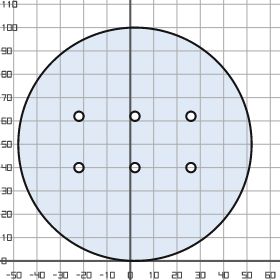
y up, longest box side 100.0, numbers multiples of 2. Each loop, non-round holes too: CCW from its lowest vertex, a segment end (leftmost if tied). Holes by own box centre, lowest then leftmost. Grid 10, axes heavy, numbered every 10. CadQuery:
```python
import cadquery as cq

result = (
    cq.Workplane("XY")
    .moveTo(2.0, 50.0)
    .circle(50.0)
    .moveTo(-22.0, 40.0)
    .circle(2.0)
    .moveTo(2.0, 40.0)
    .circle(2.0)
    .moveTo(26.0, 40.0)
    .circle(2.0)
    .moveTo(-22.0, 62.0)
    .circle(2.0)
    .moveTo(2.0, 62.0)
    .circle(2.0)
    .moveTo(26.0, 62.0)
    .circle(2.0)
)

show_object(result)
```